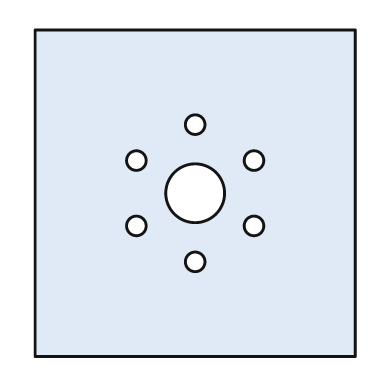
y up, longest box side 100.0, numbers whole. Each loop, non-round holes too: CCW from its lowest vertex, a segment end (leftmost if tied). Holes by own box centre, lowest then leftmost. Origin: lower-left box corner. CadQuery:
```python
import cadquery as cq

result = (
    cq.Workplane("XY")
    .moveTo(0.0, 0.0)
    .lineTo(98.0, 0.0)
    .lineTo(98.0, 100.0)
    .lineTo(0.0, 100.0)
    .close()
    .moveTo(49.0, 29.0)
    .circle(3.0)
    .moveTo(31.0, 40.0)
    .circle(3.0)
    .moveTo(67.0, 40.0)
    .circle(3.0)
    .moveTo(49.0, 50.0)
    .circle(9.0)
    .moveTo(31.0, 60.0)
    .circle(3.0)
    .moveTo(67.0, 60.0)
    .circle(3.0)
    .moveTo(49.0, 71.0)
    .circle(3.0)
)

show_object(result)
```